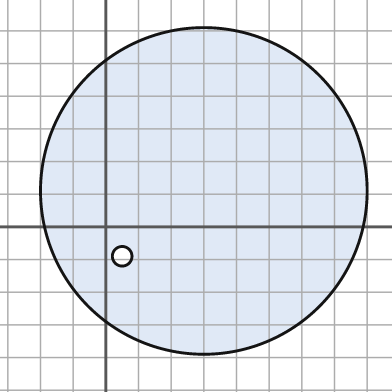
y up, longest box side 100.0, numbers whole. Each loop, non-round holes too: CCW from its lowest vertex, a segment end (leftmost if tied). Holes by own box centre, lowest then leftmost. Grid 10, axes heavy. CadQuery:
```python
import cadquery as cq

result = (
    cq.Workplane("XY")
    .moveTo(30.0, 11.0)
    .circle(50.0)
    .moveTo(5.0, -9.0)
    .circle(3.0)
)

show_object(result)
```